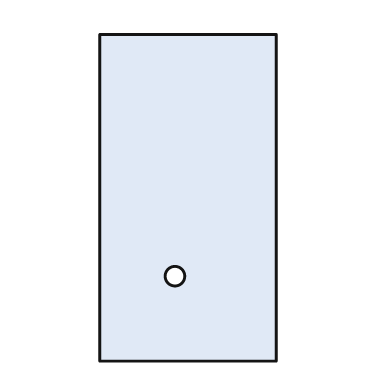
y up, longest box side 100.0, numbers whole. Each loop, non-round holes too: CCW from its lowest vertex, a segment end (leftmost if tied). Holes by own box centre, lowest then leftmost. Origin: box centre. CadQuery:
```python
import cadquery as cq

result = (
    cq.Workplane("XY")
    .moveTo(-27.0, -50.0)
    .lineTo(27.0, -50.0)
    .lineTo(27.0, 50.0)
    .lineTo(-27.0, 50.0)
    .close()
    .moveTo(-4.0, -24.0)
    .circle(3.0)
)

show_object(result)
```